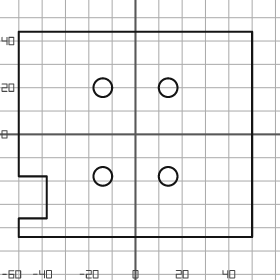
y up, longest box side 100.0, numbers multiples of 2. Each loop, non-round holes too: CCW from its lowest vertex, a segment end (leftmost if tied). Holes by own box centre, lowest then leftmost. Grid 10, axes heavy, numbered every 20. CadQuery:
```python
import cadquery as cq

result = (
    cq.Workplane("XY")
    .moveTo(-50.0, -44.0)
    .lineTo(50.0, -44.0)
    .lineTo(50.0, 44.0)
    .lineTo(-50.0, 44.0)
    .lineTo(-50.0, -18.0)
    .lineTo(-38.0, -18.0)
    .lineTo(-38.0, -36.0)
    .lineTo(-50.0, -36.0)
    .close()
    .moveTo(-14.0, -18.0)
    .circle(4.0)
    .moveTo(14.0, -18.0)
    .circle(4.0)
    .moveTo(-14.0, 20.0)
    .circle(4.0)
    .moveTo(14.0, 20.0)
    .circle(4.0)
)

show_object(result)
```